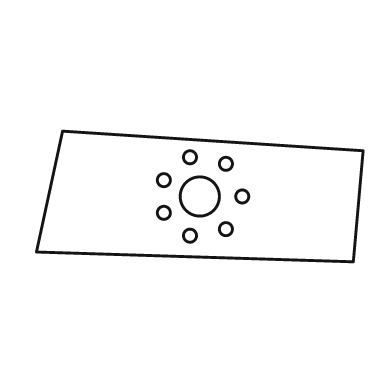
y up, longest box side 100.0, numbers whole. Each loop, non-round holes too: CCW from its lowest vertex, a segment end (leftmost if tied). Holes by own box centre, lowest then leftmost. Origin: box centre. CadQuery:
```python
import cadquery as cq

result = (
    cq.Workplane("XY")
    .moveTo(47.0, -20.0)
    .lineTo(50.0, 14.0)
    .lineTo(-42.0, 20.0)
    .lineTo(-50.0, -17.0)
    .close()
    .moveTo(-3.0, -12.0)
    .circle(2.0)
    .moveTo(8.0, -10.0)
    .circle(2.0)
    .moveTo(-11.0, -5.0)
    .circle(2.0)
    .moveTo(0.0, 0.0)
    .circle(6.0)
    .moveTo(13.0, 0.0)
    .circle(2.0)
    .moveTo(-11.0, 5.0)
    .circle(2.0)
    .moveTo(8.0, 10.0)
    .circle(2.0)
    .moveTo(-3.0, 12.0)
    .circle(2.0)
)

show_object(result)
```